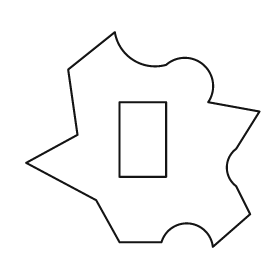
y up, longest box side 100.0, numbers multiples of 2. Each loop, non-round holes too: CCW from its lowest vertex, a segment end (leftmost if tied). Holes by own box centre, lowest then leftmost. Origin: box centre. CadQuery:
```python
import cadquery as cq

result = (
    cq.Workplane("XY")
    .moveTo(30.0, -46.0)
    .lineTo(46.0, -32.0)
    .lineTo(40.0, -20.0)
    .threePointArc((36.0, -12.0), (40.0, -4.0))
    .lineTo(50.0, 12.0)
    .lineTo(28.0, 16.0)
    .threePointArc((26.0, 32.0), (10.0, 32.0))
    .threePointArc((-4.0, 34.0), (-12.0, 46.0))
    .lineTo(-32.0, 30.0)
    .lineTo(-28.0, 2.0)
    .lineTo(-50.0, -10.0)
    .lineTo(-20.0, -26.0)
    .lineTo(-10.0, -44.0)
    .lineTo(8.0, -44.0)
    .threePointArc((20.0, -36.0), (30.0, -46.0))
    .close()
    .moveTo(-10.0, -16.0)
    .lineTo(10.0, -16.0)
    .lineTo(10.0, 16.0)
    .lineTo(-10.0, 16.0)
    .close()
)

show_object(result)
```